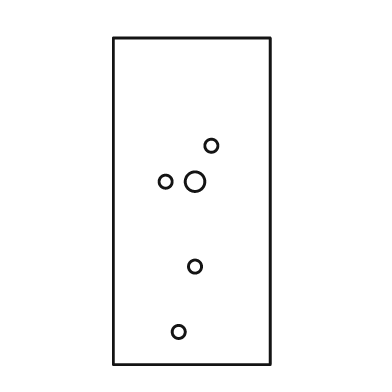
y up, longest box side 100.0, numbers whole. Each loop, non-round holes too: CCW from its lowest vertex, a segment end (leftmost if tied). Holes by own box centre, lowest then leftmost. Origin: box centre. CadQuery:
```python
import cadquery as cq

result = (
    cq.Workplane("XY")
    .moveTo(-24.0, -50.0)
    .lineTo(24.0, -50.0)
    .lineTo(24.0, 50.0)
    .lineTo(-24.0, 50.0)
    .close()
    .moveTo(-4.0, -40.0)
    .circle(2.0)
    .moveTo(1.0, -20.0)
    .circle(2.0)
    .moveTo(-8.0, 6.0)
    .circle(2.0)
    .moveTo(1.0, 6.0)
    .circle(3.0)
    .moveTo(6.0, 17.0)
    .circle(2.0)
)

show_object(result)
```